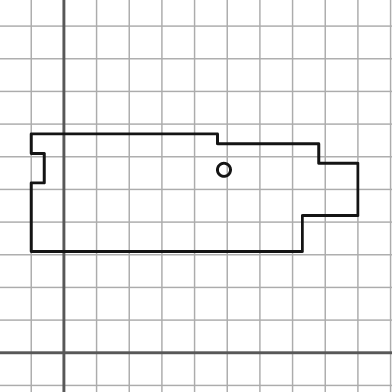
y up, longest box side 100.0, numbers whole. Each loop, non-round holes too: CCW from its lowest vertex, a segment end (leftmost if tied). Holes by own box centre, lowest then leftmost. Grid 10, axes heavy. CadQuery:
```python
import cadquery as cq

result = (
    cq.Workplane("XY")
    .moveTo(-10.0, 31.0)
    .lineTo(73.0, 31.0)
    .lineTo(73.0, 42.0)
    .lineTo(90.0, 42.0)
    .lineTo(90.0, 58.0)
    .lineTo(78.0, 58.0)
    .lineTo(78.0, 64.0)
    .lineTo(47.0, 64.0)
    .lineTo(47.0, 67.0)
    .lineTo(-10.0, 67.0)
    .lineTo(-10.0, 61.0)
    .lineTo(-6.0, 61.0)
    .lineTo(-6.0, 52.0)
    .lineTo(-10.0, 52.0)
    .close()
    .moveTo(49.0, 56.0)
    .circle(2.0)
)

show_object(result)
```